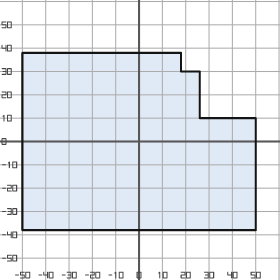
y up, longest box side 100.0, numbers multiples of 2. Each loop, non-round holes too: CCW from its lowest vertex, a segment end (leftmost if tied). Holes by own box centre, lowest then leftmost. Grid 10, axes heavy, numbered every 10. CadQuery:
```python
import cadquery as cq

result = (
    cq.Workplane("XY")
    .moveTo(-50.0, -38.0)
    .lineTo(50.0, -38.0)
    .lineTo(50.0, 10.0)
    .lineTo(26.0, 10.0)
    .lineTo(26.0, 30.0)
    .lineTo(18.0, 30.0)
    .lineTo(18.0, 38.0)
    .lineTo(-50.0, 38.0)
    .close()
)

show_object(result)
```